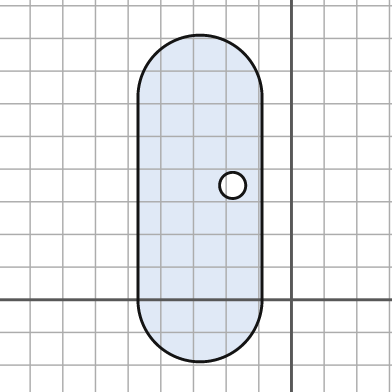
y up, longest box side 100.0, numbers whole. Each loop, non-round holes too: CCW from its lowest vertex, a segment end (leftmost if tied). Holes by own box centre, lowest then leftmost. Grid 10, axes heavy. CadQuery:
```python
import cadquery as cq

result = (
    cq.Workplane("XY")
    .moveTo(-47.0, 0.0)
    .threePointArc((-28.0, -19.0), (-9.0, 0.0))
    .lineTo(-9.0, 62.0)
    .threePointArc((-28.0, 81.0), (-47.0, 62.0))
    .close()
    .moveTo(-18.0, 35.0)
    .circle(4.0)
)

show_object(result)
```